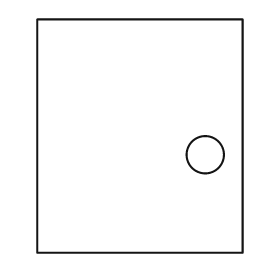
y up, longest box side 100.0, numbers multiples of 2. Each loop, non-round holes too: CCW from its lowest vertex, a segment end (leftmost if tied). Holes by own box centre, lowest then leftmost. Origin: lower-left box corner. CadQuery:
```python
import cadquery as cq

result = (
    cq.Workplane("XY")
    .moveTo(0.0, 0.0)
    .lineTo(88.0, 0.0)
    .lineTo(88.0, 100.0)
    .lineTo(0.0, 100.0)
    .close()
    .moveTo(72.0, 42.0)
    .circle(8.0)
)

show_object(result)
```